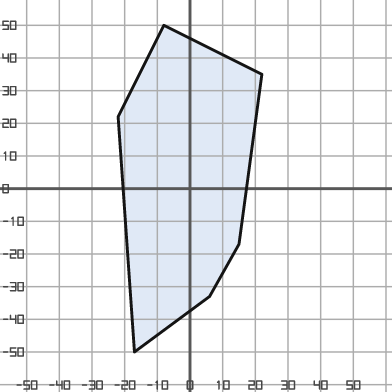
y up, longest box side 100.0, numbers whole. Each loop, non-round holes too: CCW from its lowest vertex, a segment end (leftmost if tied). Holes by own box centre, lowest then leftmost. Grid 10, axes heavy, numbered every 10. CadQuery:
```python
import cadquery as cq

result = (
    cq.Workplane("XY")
    .moveTo(-17.0, -50.0)
    .lineTo(6.0, -33.0)
    .lineTo(15.0, -17.0)
    .lineTo(22.0, 35.0)
    .lineTo(-8.0, 50.0)
    .lineTo(-22.0, 22.0)
    .close()
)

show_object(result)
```